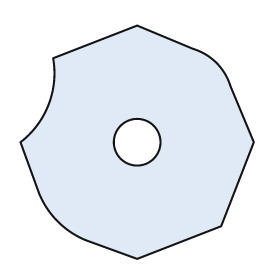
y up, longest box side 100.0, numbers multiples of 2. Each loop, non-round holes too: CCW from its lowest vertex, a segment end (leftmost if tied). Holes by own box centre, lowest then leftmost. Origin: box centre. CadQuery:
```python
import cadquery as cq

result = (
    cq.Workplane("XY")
    .moveTo(0.0, -50.0)
    .lineTo(36.0, -36.0)
    .lineTo(50.0, 0.0)
    .lineTo(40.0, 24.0)
    .threePointArc((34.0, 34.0), (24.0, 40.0))
    .lineTo(0.0, 50.0)
    .lineTo(-36.0, 36.0)
    .threePointArc((-38.0, 16.0), (-50.0, 0.0))
    .lineTo(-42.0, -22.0)
    .threePointArc((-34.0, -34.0), (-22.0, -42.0))
    .close()
    .moveTo(0.0, 0.0)
    .circle(10.0)
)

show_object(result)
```